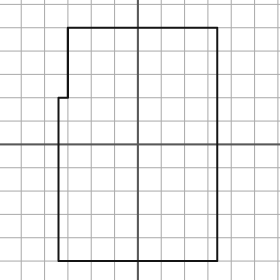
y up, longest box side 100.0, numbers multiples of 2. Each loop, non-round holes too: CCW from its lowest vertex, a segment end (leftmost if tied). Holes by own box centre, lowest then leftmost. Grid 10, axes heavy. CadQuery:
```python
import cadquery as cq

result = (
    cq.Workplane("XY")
    .moveTo(-34.0, -50.0)
    .lineTo(34.0, -50.0)
    .lineTo(34.0, 50.0)
    .lineTo(-30.0, 50.0)
    .lineTo(-30.0, 20.0)
    .lineTo(-34.0, 20.0)
    .close()
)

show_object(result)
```